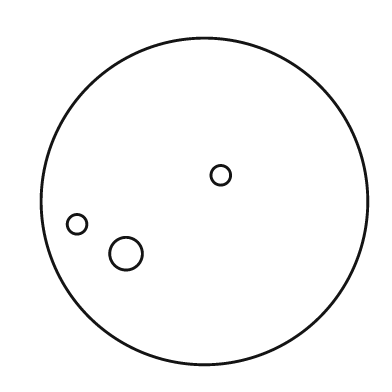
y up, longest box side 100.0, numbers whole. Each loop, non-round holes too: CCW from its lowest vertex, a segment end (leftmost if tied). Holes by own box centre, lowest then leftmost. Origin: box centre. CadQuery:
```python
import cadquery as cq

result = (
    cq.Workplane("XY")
    .moveTo(0.0, 0.0)
    .circle(50.0)
    .moveTo(-24.0, -16.0)
    .circle(5.0)
    .moveTo(-39.0, -7.0)
    .circle(3.0)
    .moveTo(5.0, 8.0)
    .circle(3.0)
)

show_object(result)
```